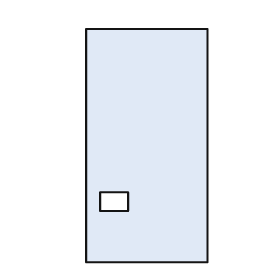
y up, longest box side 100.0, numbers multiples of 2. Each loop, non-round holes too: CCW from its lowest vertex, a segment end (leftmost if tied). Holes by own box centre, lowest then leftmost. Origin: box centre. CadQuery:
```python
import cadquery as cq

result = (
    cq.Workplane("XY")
    .moveTo(-26.0, -50.0)
    .lineTo(26.0, -50.0)
    .lineTo(26.0, 50.0)
    .lineTo(-26.0, 50.0)
    .close()
    .moveTo(-20.0, -28.0)
    .lineTo(-8.0, -28.0)
    .lineTo(-8.0, -20.0)
    .lineTo(-20.0, -20.0)
    .close()
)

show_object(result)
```